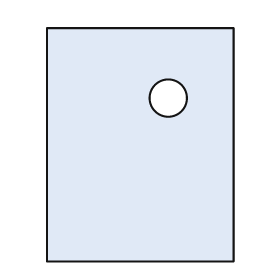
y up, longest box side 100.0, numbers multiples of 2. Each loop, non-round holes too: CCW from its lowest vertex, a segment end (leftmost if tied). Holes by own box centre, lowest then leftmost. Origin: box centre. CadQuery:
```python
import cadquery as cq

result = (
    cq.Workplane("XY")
    .moveTo(-40.0, -50.0)
    .lineTo(40.0, -50.0)
    .lineTo(40.0, 50.0)
    .lineTo(-40.0, 50.0)
    .close()
    .moveTo(12.0, 20.0)
    .circle(8.0)
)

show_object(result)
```